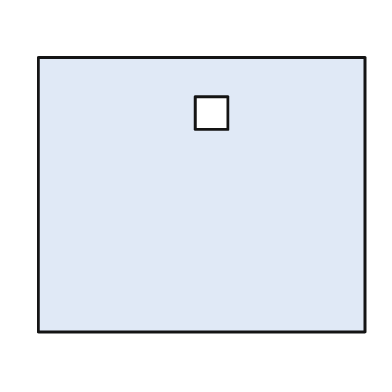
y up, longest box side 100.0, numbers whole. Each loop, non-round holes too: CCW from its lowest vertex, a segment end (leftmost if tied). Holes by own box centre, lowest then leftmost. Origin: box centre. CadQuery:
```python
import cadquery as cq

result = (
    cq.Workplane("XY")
    .moveTo(-50.0, -42.0)
    .lineTo(50.0, -42.0)
    .lineTo(50.0, 42.0)
    .lineTo(-50.0, 42.0)
    .close()
    .moveTo(-2.0, 20.0)
    .lineTo(8.0, 20.0)
    .lineTo(8.0, 30.0)
    .lineTo(-2.0, 30.0)
    .close()
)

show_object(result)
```